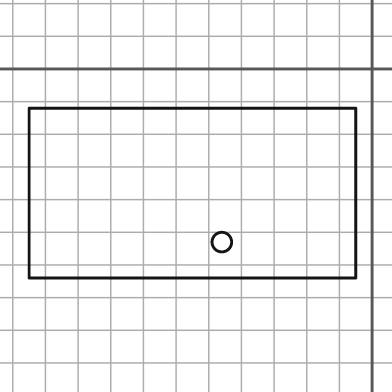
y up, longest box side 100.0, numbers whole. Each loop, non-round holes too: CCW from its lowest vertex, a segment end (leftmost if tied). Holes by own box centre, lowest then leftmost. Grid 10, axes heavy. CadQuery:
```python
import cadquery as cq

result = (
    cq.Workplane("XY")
    .moveTo(-105.0, -64.0)
    .lineTo(-5.0, -64.0)
    .lineTo(-5.0, -12.0)
    .lineTo(-105.0, -12.0)
    .close()
    .moveTo(-46.0, -53.0)
    .circle(3.0)
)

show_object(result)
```